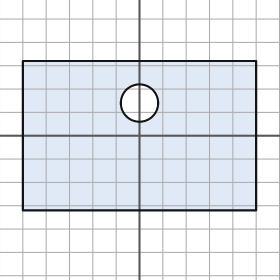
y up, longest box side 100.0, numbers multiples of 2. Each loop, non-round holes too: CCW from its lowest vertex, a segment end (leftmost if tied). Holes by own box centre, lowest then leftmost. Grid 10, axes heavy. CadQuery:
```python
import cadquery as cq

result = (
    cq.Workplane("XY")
    .moveTo(-50.0, -32.0)
    .lineTo(50.0, -32.0)
    .lineTo(50.0, 32.0)
    .lineTo(-50.0, 32.0)
    .close()
    .moveTo(0.0, 14.0)
    .circle(8.0)
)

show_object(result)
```